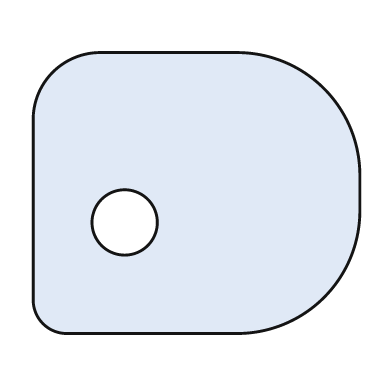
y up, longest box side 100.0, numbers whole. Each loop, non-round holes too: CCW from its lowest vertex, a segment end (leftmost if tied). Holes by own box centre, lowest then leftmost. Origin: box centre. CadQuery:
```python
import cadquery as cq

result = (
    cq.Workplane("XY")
    .moveTo(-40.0, -43.0)
    .lineTo(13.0, -43.0)
    .threePointArc((39.0, -32.0), (50.0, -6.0))
    .lineTo(50.0, 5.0)
    .threePointArc((39.0, 32.0), (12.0, 43.0))
    .lineTo(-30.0, 43.0)
    .threePointArc((-44.0, 37.0), (-50.0, 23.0))
    .lineTo(-50.0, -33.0)
    .threePointArc((-47.0, -40.0), (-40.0, -43.0))
    .close()
    .moveTo(-22.0, -9.0)
    .circle(10.0)
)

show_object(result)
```